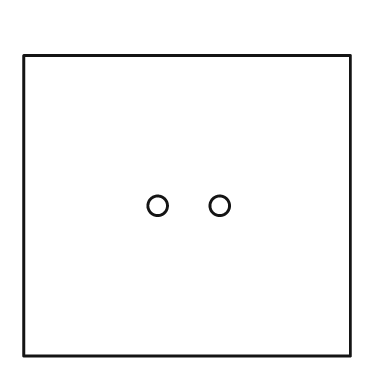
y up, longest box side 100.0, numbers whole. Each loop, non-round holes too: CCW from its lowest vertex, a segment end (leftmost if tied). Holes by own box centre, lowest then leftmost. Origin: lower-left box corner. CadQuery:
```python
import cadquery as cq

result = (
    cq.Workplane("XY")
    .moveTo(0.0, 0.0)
    .lineTo(100.0, 0.0)
    .lineTo(100.0, 92.0)
    .lineTo(0.0, 92.0)
    .close()
    .moveTo(41.0, 46.0)
    .circle(3.0)
    .moveTo(60.0, 46.0)
    .circle(3.0)
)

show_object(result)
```